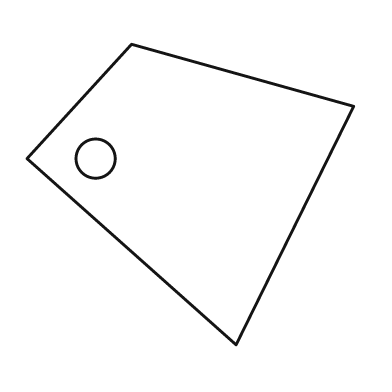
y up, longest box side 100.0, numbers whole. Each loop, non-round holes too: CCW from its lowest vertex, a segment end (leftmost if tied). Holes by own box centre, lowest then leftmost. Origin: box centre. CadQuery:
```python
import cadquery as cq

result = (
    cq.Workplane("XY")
    .moveTo(14.0, -46.0)
    .lineTo(50.0, 27.0)
    .lineTo(-18.0, 46.0)
    .lineTo(-50.0, 11.0)
    .close()
    .moveTo(-29.0, 11.0)
    .circle(6.0)
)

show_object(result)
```